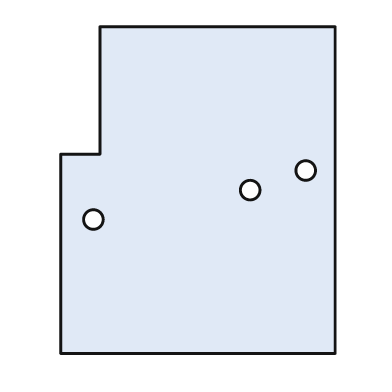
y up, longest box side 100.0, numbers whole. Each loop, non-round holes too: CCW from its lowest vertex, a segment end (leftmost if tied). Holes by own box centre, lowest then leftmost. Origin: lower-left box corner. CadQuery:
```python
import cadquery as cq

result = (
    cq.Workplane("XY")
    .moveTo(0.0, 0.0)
    .lineTo(84.0, 0.0)
    .lineTo(84.0, 100.0)
    .lineTo(12.0, 100.0)
    .lineTo(12.0, 61.0)
    .lineTo(0.0, 61.0)
    .close()
    .moveTo(10.0, 41.0)
    .circle(3.0)
    .moveTo(58.0, 50.0)
    .circle(3.0)
    .moveTo(75.0, 56.0)
    .circle(3.0)
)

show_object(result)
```